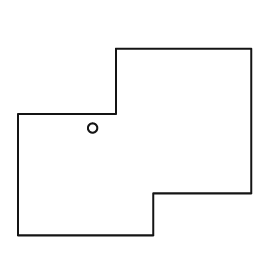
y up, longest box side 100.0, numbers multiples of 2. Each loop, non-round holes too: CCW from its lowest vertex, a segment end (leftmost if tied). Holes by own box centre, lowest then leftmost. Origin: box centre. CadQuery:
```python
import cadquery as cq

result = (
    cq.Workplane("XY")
    .moveTo(-50.0, -40.0)
    .lineTo(8.0, -40.0)
    .lineTo(8.0, -22.0)
    .lineTo(50.0, -22.0)
    .lineTo(50.0, 40.0)
    .lineTo(-8.0, 40.0)
    .lineTo(-8.0, 12.0)
    .lineTo(-50.0, 12.0)
    .close()
    .moveTo(-18.0, 6.0)
    .circle(2.0)
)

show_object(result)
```